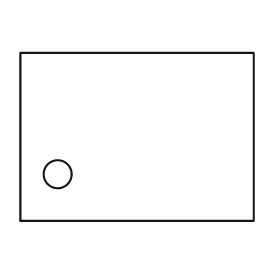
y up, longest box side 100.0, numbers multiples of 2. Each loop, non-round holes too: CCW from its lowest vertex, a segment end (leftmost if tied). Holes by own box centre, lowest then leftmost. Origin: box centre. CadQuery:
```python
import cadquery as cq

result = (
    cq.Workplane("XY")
    .moveTo(-50.0, -36.0)
    .lineTo(50.0, -36.0)
    .lineTo(50.0, 36.0)
    .lineTo(-50.0, 36.0)
    .close()
    .moveTo(-34.0, -16.0)
    .circle(6.0)
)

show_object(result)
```